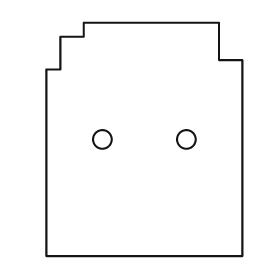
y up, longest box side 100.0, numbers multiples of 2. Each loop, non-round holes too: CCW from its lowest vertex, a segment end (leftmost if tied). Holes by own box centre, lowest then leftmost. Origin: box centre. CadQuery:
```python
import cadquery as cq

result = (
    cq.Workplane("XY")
    .moveTo(-42.0, -50.0)
    .lineTo(42.0, -50.0)
    .lineTo(42.0, 34.0)
    .lineTo(32.0, 34.0)
    .lineTo(32.0, 50.0)
    .lineTo(-26.0, 50.0)
    .lineTo(-26.0, 44.0)
    .lineTo(-36.0, 44.0)
    .lineTo(-36.0, 30.0)
    .lineTo(-42.0, 30.0)
    .close()
    .moveTo(-18.0, 0.0)
    .circle(4.0)
    .moveTo(18.0, 0.0)
    .circle(4.0)
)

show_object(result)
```